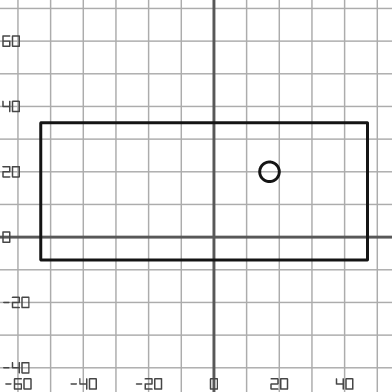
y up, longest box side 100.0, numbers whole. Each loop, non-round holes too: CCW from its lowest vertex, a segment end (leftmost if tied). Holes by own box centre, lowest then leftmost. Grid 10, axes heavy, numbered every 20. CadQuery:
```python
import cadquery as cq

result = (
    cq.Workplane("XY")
    .moveTo(-53.0, -7.0)
    .lineTo(47.0, -7.0)
    .lineTo(47.0, 35.0)
    .lineTo(-53.0, 35.0)
    .close()
    .moveTo(17.0, 20.0)
    .circle(3.0)
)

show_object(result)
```